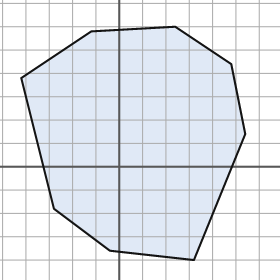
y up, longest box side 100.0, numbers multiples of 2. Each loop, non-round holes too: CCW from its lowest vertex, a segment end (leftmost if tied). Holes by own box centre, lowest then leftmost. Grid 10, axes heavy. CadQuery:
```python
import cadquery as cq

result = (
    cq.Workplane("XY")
    .moveTo(32.0, -40.0)
    .lineTo(54.0, 14.0)
    .lineTo(48.0, 44.0)
    .lineTo(24.0, 60.0)
    .lineTo(-12.0, 58.0)
    .lineTo(-42.0, 38.0)
    .lineTo(-28.0, -18.0)
    .lineTo(-4.0, -36.0)
    .close()
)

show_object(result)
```